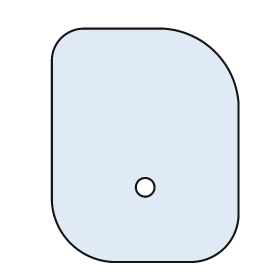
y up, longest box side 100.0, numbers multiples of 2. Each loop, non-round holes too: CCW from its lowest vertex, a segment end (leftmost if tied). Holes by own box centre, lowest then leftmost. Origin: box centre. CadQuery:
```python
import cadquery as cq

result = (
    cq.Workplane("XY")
    .moveTo(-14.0, -50.0)
    .lineTo(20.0, -50.0)
    .threePointArc((34.0, -44.0), (40.0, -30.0))
    .lineTo(40.0, 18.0)
    .threePointArc((30.0, 40.0), (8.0, 50.0))
    .lineTo(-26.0, 50.0)
    .threePointArc((-36.0, 46.0), (-40.0, 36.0))
    .lineTo(-40.0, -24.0)
    .threePointArc((-32.0, -42.0), (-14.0, -50.0))
    .close()
    .moveTo(0.0, -18.0)
    .circle(4.0)
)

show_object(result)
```